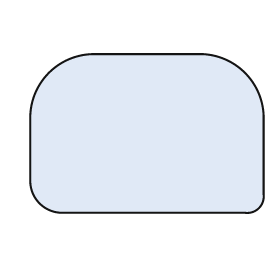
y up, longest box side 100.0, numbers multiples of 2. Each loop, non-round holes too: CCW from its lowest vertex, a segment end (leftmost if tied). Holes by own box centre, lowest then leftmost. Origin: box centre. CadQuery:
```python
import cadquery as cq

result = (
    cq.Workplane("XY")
    .moveTo(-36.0, -34.0)
    .lineTo(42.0, -34.0)
    .threePointArc((48.0, -32.0), (50.0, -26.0))
    .lineTo(50.0, 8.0)
    .threePointArc((42.0, 26.0), (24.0, 34.0))
    .lineTo(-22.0, 34.0)
    .threePointArc((-42.0, 26.0), (-50.0, 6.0))
    .lineTo(-50.0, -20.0)
    .threePointArc((-46.0, -30.0), (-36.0, -34.0))
    .close()
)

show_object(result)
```